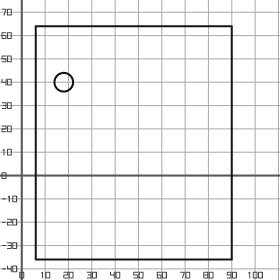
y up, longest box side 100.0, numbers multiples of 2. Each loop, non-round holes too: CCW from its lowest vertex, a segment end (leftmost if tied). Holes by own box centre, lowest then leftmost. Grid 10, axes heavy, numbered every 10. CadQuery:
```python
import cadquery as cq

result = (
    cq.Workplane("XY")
    .moveTo(6.0, -36.0)
    .lineTo(90.0, -36.0)
    .lineTo(90.0, 64.0)
    .lineTo(6.0, 64.0)
    .close()
    .moveTo(18.0, 40.0)
    .circle(4.0)
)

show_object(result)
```